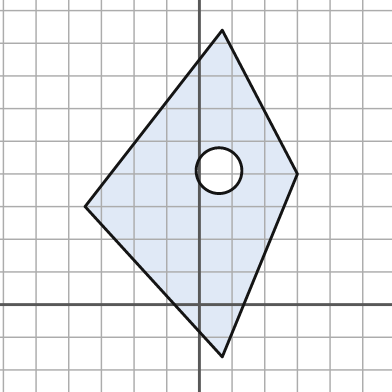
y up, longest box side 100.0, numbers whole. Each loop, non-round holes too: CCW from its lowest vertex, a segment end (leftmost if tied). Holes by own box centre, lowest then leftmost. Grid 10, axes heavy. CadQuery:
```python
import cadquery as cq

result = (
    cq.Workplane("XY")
    .moveTo(7.0, -16.0)
    .lineTo(30.0, 40.0)
    .lineTo(7.0, 84.0)
    .lineTo(-35.0, 30.0)
    .close()
    .moveTo(6.0, 41.0)
    .circle(7.0)
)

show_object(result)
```